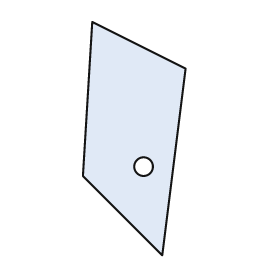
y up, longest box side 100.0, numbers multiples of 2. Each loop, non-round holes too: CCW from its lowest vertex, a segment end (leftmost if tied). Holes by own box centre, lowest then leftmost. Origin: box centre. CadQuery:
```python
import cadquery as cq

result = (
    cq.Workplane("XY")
    .moveTo(12.0, -50.0)
    .lineTo(22.0, 30.0)
    .lineTo(-18.0, 50.0)
    .lineTo(-22.0, -16.0)
    .close()
    .moveTo(4.0, -12.0)
    .circle(4.0)
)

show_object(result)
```